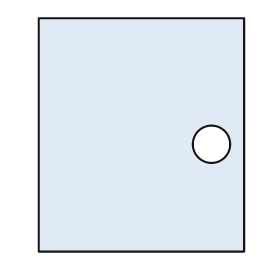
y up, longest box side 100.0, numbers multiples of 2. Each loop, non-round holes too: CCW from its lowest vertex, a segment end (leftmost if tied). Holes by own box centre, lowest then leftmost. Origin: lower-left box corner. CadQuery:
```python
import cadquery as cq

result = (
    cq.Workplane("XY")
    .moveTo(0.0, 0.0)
    .lineTo(88.0, 0.0)
    .lineTo(88.0, 100.0)
    .lineTo(0.0, 100.0)
    .close()
    .moveTo(74.0, 46.0)
    .circle(8.0)
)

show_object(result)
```